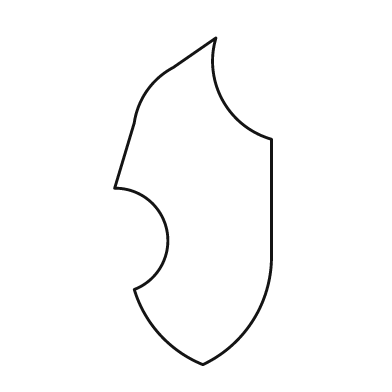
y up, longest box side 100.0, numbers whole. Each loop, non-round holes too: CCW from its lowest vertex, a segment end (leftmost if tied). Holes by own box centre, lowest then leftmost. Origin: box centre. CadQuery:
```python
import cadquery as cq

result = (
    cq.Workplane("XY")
    .moveTo(3.0, -50.0)
    .threePointArc((18.0, -37.0), (24.0, -18.0))
    .lineTo(24.0, 19.0)
    .threePointArc((9.0, 31.0), (7.0, 50.0))
    .lineTo(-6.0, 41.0)
    .threePointArc((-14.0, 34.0), (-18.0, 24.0))
    .lineTo(-24.0, 4.0)
    .threePointArc((-8.0, -9.0), (-18.0, -27.0))
    .threePointArc((-10.0, -41.0), (3.0, -50.0))
    .close()
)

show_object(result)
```